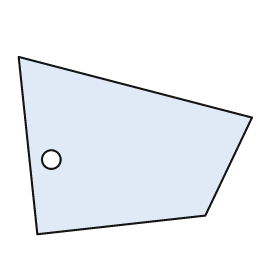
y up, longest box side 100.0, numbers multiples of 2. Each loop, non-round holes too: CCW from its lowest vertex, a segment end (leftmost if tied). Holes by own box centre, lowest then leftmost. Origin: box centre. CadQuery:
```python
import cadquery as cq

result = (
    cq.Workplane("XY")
    .moveTo(-42.0, -38.0)
    .lineTo(30.0, -30.0)
    .lineTo(50.0, 12.0)
    .lineTo(-50.0, 38.0)
    .close()
    .moveTo(-36.0, -6.0)
    .circle(4.0)
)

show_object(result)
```